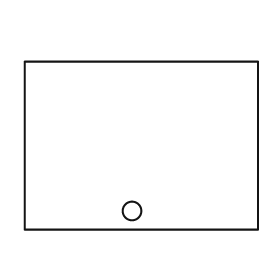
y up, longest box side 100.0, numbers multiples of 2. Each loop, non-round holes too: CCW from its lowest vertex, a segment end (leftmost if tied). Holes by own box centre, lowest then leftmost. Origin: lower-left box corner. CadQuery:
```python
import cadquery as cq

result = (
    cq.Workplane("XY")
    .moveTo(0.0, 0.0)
    .lineTo(100.0, 0.0)
    .lineTo(100.0, 72.0)
    .lineTo(0.0, 72.0)
    .close()
    .moveTo(46.0, 8.0)
    .circle(4.0)
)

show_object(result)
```